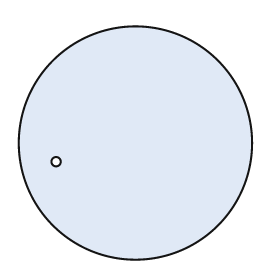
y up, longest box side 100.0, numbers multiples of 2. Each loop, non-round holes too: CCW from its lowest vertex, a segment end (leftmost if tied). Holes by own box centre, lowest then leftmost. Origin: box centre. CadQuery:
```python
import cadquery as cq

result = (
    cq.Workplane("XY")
    .moveTo(0.0, 0.0)
    .circle(50.0)
    .moveTo(-34.0, -8.0)
    .circle(2.0)
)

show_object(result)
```